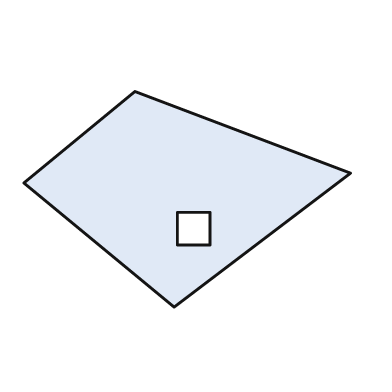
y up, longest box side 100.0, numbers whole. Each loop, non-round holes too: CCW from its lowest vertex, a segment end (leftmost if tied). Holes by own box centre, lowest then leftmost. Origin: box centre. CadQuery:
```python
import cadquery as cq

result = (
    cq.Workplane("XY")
    .moveTo(-4.0, -33.0)
    .lineTo(50.0, 8.0)
    .lineTo(-16.0, 33.0)
    .lineTo(-50.0, 5.0)
    .close()
    .moveTo(-3.0, -14.0)
    .lineTo(7.0, -14.0)
    .lineTo(7.0, -4.0)
    .lineTo(-3.0, -4.0)
    .close()
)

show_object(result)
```